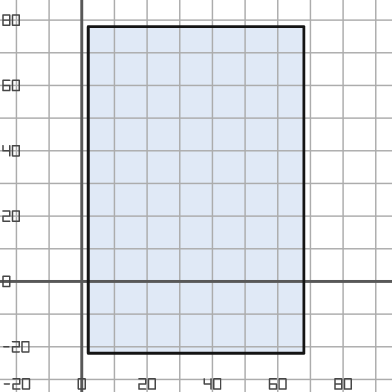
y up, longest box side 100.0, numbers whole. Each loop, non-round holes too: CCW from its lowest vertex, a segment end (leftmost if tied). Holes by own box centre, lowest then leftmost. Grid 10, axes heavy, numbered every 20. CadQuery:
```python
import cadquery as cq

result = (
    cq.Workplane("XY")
    .moveTo(2.0, -22.0)
    .lineTo(68.0, -22.0)
    .lineTo(68.0, 78.0)
    .lineTo(2.0, 78.0)
    .close()
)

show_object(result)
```